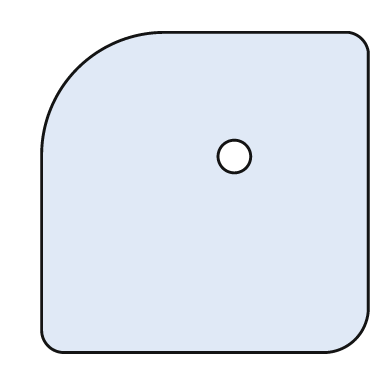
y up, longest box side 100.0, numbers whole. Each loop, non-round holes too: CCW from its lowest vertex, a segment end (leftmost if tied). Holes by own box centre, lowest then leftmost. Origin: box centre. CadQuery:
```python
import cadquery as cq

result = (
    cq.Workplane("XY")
    .moveTo(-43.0, -49.0)
    .lineTo(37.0, -49.0)
    .threePointArc((46.0, -45.0), (50.0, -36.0))
    .lineTo(50.0, 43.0)
    .threePointArc((48.0, 47.0), (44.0, 49.0))
    .lineTo(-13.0, 49.0)
    .threePointArc((-39.0, 38.0), (-50.0, 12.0))
    .lineTo(-50.0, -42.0)
    .threePointArc((-48.0, -47.0), (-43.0, -49.0))
    .close()
    .moveTo(9.0, 11.0)
    .circle(5.0)
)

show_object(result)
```